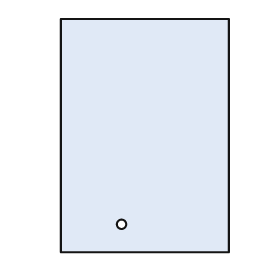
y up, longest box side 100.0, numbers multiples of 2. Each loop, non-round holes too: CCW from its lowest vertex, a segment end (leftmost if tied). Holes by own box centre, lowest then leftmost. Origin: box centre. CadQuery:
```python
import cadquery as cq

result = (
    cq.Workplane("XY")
    .moveTo(-36.0, -50.0)
    .lineTo(36.0, -50.0)
    .lineTo(36.0, 50.0)
    .lineTo(-36.0, 50.0)
    .close()
    .moveTo(-10.0, -38.0)
    .circle(2.0)
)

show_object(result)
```